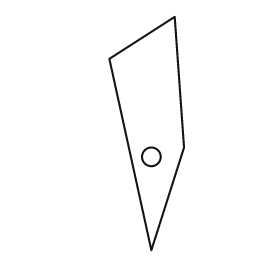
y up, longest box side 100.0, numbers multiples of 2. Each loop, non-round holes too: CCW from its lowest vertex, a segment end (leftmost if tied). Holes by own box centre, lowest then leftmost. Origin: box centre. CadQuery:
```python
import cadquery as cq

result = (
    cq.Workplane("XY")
    .moveTo(2.0, -50.0)
    .lineTo(16.0, -6.0)
    .lineTo(12.0, 50.0)
    .lineTo(-16.0, 32.0)
    .close()
    .moveTo(2.0, -10.0)
    .circle(4.0)
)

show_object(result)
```